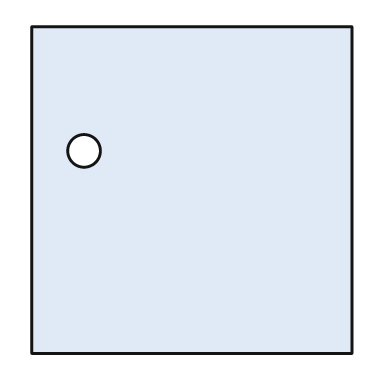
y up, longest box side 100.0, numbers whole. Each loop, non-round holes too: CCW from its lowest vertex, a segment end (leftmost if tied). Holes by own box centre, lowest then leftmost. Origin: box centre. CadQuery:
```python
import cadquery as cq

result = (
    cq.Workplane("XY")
    .moveTo(-49.0, -50.0)
    .lineTo(49.0, -50.0)
    .lineTo(49.0, 50.0)
    .lineTo(-49.0, 50.0)
    .close()
    .moveTo(-33.0, 12.0)
    .circle(5.0)
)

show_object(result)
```